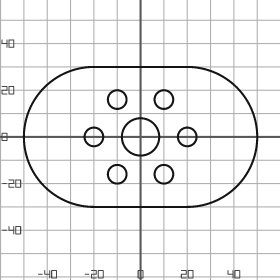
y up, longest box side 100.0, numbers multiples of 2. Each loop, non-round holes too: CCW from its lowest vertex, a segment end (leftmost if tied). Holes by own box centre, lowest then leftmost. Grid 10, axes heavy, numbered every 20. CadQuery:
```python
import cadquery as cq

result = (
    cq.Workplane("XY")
    .moveTo(-20.0, -30.0)
    .lineTo(20.0, -30.0)
    .threePointArc((50.0, 0.0), (20.0, 30.0))
    .lineTo(-20.0, 30.0)
    .threePointArc((-50.0, 0.0), (-20.0, -30.0))
    .close()
    .moveTo(-10.0, -16.0)
    .circle(4.0)
    .moveTo(10.0, -16.0)
    .circle(4.0)
    .moveTo(-20.0, 0.0)
    .circle(4.0)
    .moveTo(0.0, 0.0)
    .circle(8.0)
    .moveTo(20.0, 0.0)
    .circle(4.0)
    .moveTo(-10.0, 16.0)
    .circle(4.0)
    .moveTo(10.0, 16.0)
    .circle(4.0)
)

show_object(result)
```